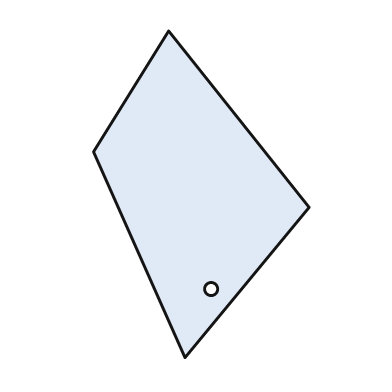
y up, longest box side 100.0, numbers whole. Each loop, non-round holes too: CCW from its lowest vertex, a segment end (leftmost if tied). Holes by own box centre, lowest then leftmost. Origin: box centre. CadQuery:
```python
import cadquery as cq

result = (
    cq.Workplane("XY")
    .moveTo(-5.0, -50.0)
    .lineTo(33.0, -4.0)
    .lineTo(-10.0, 50.0)
    .lineTo(-33.0, 13.0)
    .close()
    .moveTo(3.0, -29.0)
    .circle(2.0)
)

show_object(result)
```